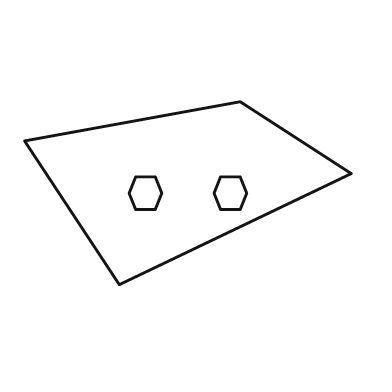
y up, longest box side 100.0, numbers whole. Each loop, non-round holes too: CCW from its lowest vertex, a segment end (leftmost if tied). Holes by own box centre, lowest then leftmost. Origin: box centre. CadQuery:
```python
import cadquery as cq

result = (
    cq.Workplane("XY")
    .moveTo(-21.0, -28.0)
    .lineTo(50.0, 6.0)
    .lineTo(16.0, 28.0)
    .lineTo(-50.0, 16.0)
    .close()
    .moveTo(-16.0, -5.0)
    .lineTo(-10.0, -5.0)
    .lineTo(-8.0, 0.0)
    .lineTo(-10.0, 5.0)
    .lineTo(-16.0, 5.0)
    .lineTo(-18.0, 0.0)
    .close()
    .moveTo(10.0, -5.0)
    .lineTo(16.0, -5.0)
    .lineTo(18.0, 0.0)
    .lineTo(16.0, 5.0)
    .lineTo(10.0, 5.0)
    .lineTo(8.0, 0.0)
    .close()
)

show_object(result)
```